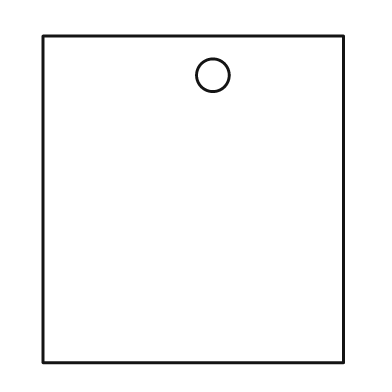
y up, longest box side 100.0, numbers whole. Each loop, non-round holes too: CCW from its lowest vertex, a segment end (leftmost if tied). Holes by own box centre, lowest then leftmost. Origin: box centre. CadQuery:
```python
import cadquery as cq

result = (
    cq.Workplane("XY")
    .moveTo(-46.0, -50.0)
    .lineTo(46.0, -50.0)
    .lineTo(46.0, 50.0)
    .lineTo(-46.0, 50.0)
    .close()
    .moveTo(6.0, 38.0)
    .circle(5.0)
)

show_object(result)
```